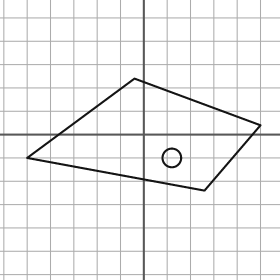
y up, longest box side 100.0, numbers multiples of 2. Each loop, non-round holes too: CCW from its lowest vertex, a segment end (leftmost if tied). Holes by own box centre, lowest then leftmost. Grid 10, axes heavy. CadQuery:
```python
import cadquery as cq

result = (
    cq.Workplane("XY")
    .moveTo(26.0, -24.0)
    .lineTo(50.0, 4.0)
    .lineTo(-4.0, 24.0)
    .lineTo(-50.0, -10.0)
    .close()
    .moveTo(12.0, -10.0)
    .circle(4.0)
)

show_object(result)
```